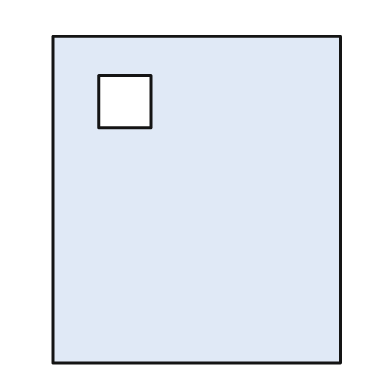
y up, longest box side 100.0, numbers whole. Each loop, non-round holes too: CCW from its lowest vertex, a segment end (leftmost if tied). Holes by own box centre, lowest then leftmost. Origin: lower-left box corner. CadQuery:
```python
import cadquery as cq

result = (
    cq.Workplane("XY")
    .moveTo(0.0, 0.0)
    .lineTo(88.0, 0.0)
    .lineTo(88.0, 100.0)
    .lineTo(0.0, 100.0)
    .close()
    .moveTo(14.0, 72.0)
    .lineTo(30.0, 72.0)
    .lineTo(30.0, 88.0)
    .lineTo(14.0, 88.0)
    .close()
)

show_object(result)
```